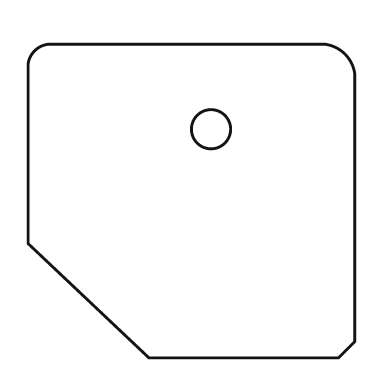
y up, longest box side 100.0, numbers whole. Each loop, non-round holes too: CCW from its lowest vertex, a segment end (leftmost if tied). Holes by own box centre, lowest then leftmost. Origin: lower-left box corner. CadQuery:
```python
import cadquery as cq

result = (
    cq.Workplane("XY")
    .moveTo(37.0, 0.0)
    .lineTo(95.0, 0.0)
    .lineTo(100.0, 5.0)
    .lineTo(100.0, 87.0)
    .threePointArc((97.0, 93.0), (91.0, 96.0))
    .lineTo(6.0, 96.0)
    .threePointArc((2.0, 94.0), (0.0, 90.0))
    .lineTo(0.0, 35.0)
    .close()
    .moveTo(56.0, 70.0)
    .circle(6.0)
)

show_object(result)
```